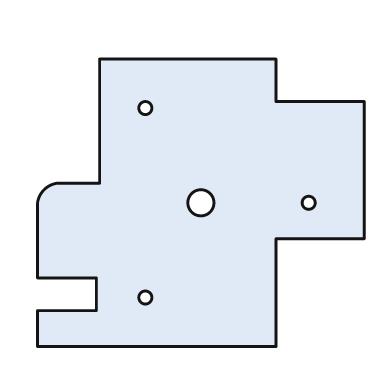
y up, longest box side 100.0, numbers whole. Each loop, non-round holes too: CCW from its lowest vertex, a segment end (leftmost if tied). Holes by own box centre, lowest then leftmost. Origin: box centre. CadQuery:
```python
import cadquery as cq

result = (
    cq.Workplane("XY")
    .moveTo(-50.0, -44.0)
    .lineTo(23.0, -44.0)
    .lineTo(23.0, -11.0)
    .lineTo(50.0, -11.0)
    .lineTo(50.0, 31.0)
    .lineTo(23.0, 31.0)
    .lineTo(23.0, 44.0)
    .lineTo(-31.0, 44.0)
    .lineTo(-31.0, 6.0)
    .lineTo(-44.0, 6.0)
    .threePointArc((-48.0, 4.0), (-50.0, 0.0))
    .lineTo(-50.0, -23.0)
    .lineTo(-32.0, -23.0)
    .lineTo(-32.0, -33.0)
    .lineTo(-50.0, -33.0)
    .close()
    .moveTo(-17.0, -29.0)
    .circle(2.0)
    .moveTo(0.0, 0.0)
    .circle(4.0)
    .moveTo(33.0, 0.0)
    .circle(2.0)
    .moveTo(-17.0, 29.0)
    .circle(2.0)
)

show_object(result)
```